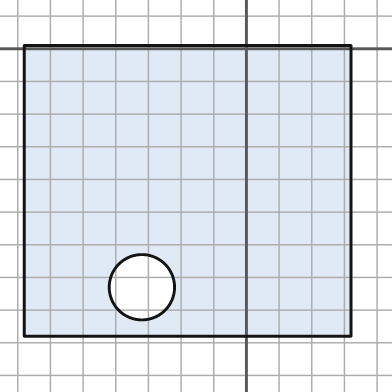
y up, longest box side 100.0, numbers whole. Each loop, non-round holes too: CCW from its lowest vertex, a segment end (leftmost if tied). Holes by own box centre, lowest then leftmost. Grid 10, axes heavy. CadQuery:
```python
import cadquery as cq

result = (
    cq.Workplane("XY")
    .moveTo(-68.0, -88.0)
    .lineTo(32.0, -88.0)
    .lineTo(32.0, 1.0)
    .lineTo(-68.0, 1.0)
    .close()
    .moveTo(-32.0, -73.0)
    .circle(10.0)
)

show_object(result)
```